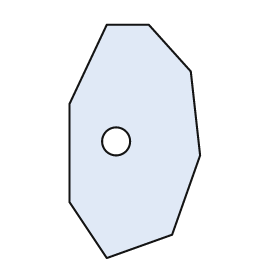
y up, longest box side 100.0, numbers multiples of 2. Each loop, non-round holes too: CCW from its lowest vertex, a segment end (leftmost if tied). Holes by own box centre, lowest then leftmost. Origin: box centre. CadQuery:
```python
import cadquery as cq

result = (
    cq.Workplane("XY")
    .moveTo(-12.0, -50.0)
    .lineTo(16.0, -40.0)
    .lineTo(28.0, -6.0)
    .lineTo(24.0, 30.0)
    .lineTo(6.0, 50.0)
    .lineTo(-12.0, 50.0)
    .lineTo(-28.0, 16.0)
    .lineTo(-28.0, -26.0)
    .close()
    .moveTo(-8.0, 0.0)
    .circle(6.0)
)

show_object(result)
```